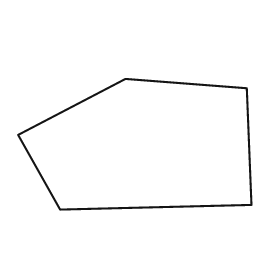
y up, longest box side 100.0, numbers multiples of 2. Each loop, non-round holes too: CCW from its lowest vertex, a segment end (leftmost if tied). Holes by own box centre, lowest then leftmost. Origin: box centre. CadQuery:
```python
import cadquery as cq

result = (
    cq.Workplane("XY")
    .moveTo(-32.0, -28.0)
    .lineTo(50.0, -26.0)
    .lineTo(48.0, 24.0)
    .lineTo(-4.0, 28.0)
    .lineTo(-50.0, 4.0)
    .close()
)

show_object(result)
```